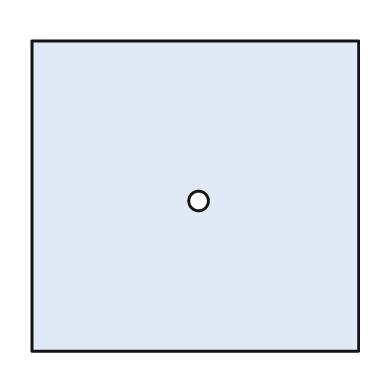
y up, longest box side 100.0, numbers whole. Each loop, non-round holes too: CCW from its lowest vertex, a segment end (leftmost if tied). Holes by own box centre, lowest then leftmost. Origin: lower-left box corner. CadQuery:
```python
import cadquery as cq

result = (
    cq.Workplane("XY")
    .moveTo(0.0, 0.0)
    .lineTo(100.0, 0.0)
    .lineTo(100.0, 95.0)
    .lineTo(0.0, 95.0)
    .close()
    .moveTo(51.0, 46.0)
    .circle(3.0)
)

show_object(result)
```